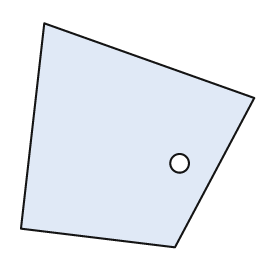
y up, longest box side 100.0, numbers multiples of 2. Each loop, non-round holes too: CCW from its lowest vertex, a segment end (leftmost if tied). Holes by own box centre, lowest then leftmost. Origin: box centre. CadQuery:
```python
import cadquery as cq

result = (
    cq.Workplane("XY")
    .moveTo(16.0, -48.0)
    .lineTo(50.0, 16.0)
    .lineTo(-40.0, 48.0)
    .lineTo(-50.0, -40.0)
    .close()
    .moveTo(18.0, -12.0)
    .circle(4.0)
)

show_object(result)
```